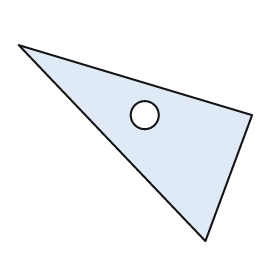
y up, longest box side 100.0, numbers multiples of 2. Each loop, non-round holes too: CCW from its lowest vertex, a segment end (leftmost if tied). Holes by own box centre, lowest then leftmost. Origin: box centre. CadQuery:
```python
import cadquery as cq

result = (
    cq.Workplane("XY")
    .moveTo(30.0, -42.0)
    .lineTo(50.0, 12.0)
    .lineTo(-50.0, 42.0)
    .close()
    .moveTo(4.0, 12.0)
    .circle(6.0)
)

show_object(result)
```